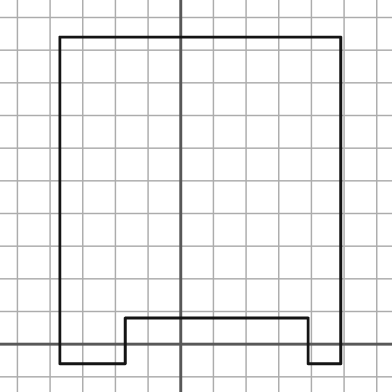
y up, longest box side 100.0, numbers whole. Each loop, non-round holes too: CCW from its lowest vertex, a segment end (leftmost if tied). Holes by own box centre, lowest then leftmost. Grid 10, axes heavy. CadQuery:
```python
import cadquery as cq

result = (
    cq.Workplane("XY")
    .moveTo(-37.0, -6.0)
    .lineTo(-17.0, -6.0)
    .lineTo(-17.0, 8.0)
    .lineTo(39.0, 8.0)
    .lineTo(39.0, -6.0)
    .lineTo(49.0, -6.0)
    .lineTo(49.0, 94.0)
    .lineTo(-37.0, 94.0)
    .close()
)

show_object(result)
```